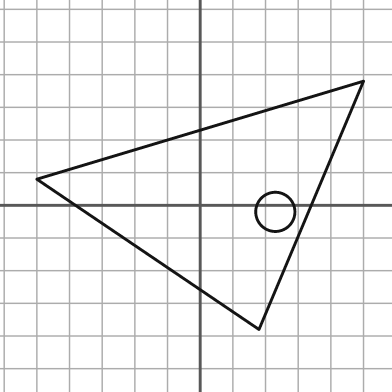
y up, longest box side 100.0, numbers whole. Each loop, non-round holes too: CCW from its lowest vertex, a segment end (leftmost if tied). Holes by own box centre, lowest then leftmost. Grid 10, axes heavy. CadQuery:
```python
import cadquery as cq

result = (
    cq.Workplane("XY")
    .moveTo(18.0, -38.0)
    .lineTo(50.0, 38.0)
    .lineTo(-50.0, 8.0)
    .close()
    .moveTo(23.0, -2.0)
    .circle(6.0)
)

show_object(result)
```